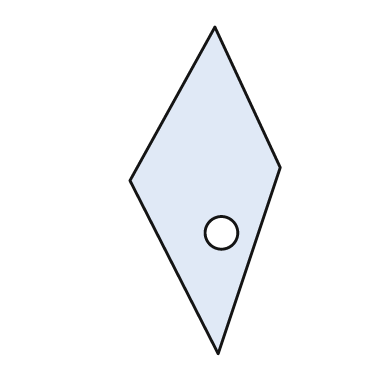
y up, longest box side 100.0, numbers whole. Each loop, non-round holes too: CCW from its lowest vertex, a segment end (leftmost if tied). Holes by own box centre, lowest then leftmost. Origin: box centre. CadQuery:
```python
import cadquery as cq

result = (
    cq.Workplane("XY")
    .moveTo(4.0, -50.0)
    .lineTo(23.0, 7.0)
    .lineTo(3.0, 50.0)
    .lineTo(-23.0, 3.0)
    .close()
    .moveTo(5.0, -13.0)
    .circle(5.0)
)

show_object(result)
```